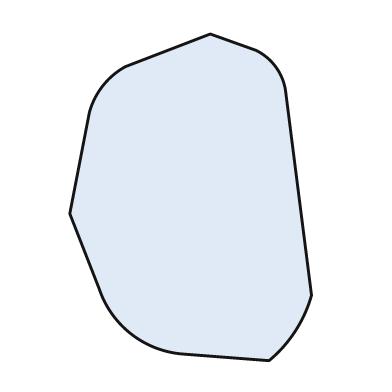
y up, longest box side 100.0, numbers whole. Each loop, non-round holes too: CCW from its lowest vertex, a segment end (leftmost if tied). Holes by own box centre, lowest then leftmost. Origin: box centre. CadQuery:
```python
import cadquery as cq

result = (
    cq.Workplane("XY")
    .moveTo(24.0, -50.0)
    .threePointArc((32.0, -41.0), (37.0, -30.0))
    .lineTo(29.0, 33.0)
    .threePointArc((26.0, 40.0), (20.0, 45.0))
    .lineTo(6.0, 50.0)
    .lineTo(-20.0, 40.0)
    .threePointArc((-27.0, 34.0), (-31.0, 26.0))
    .lineTo(-37.0, -5.0)
    .lineTo(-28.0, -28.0)
    .threePointArc((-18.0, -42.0), (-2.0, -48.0))
    .close()
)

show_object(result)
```